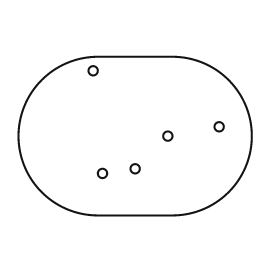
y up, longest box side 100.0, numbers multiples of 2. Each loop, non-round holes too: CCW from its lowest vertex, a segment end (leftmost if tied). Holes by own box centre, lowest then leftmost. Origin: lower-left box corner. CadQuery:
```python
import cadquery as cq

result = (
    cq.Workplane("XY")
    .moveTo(34.0, 0.0)
    .lineTo(66.0, 0.0)
    .threePointArc((100.0, 34.0), (66.0, 68.0))
    .lineTo(34.0, 68.0)
    .threePointArc((0.0, 34.0), (34.0, 0.0))
    .close()
    .moveTo(36.0, 18.0)
    .circle(2.0)
    .moveTo(50.0, 20.0)
    .circle(2.0)
    .moveTo(64.0, 34.0)
    .circle(2.0)
    .moveTo(86.0, 38.0)
    .circle(2.0)
    .moveTo(32.0, 62.0)
    .circle(2.0)
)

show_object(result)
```